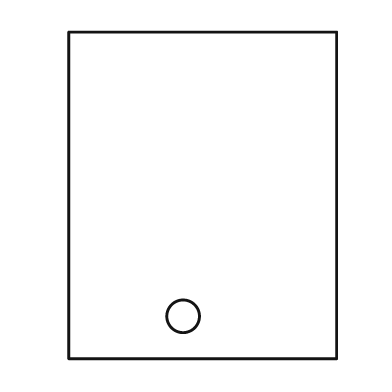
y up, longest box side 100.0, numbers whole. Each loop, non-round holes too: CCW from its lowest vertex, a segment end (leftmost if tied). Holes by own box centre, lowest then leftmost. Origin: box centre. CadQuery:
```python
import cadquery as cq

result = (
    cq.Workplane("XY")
    .moveTo(-41.0, -50.0)
    .lineTo(41.0, -50.0)
    .lineTo(41.0, 50.0)
    .lineTo(-41.0, 50.0)
    .close()
    .moveTo(-6.0, -37.0)
    .circle(5.0)
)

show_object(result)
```